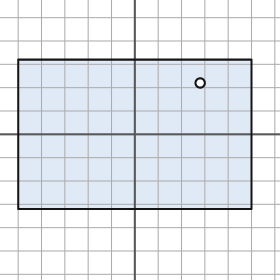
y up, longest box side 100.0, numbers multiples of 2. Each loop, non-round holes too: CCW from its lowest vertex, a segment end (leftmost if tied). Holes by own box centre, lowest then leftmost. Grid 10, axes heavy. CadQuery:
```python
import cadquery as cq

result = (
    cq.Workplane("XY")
    .moveTo(-50.0, -32.0)
    .lineTo(50.0, -32.0)
    .lineTo(50.0, 32.0)
    .lineTo(-50.0, 32.0)
    .close()
    .moveTo(28.0, 22.0)
    .circle(2.0)
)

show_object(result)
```